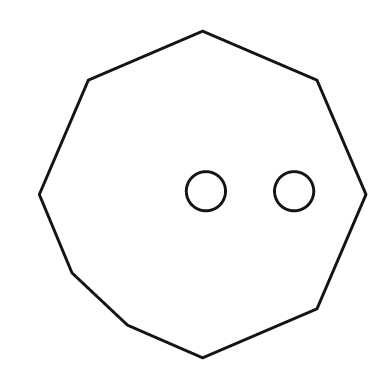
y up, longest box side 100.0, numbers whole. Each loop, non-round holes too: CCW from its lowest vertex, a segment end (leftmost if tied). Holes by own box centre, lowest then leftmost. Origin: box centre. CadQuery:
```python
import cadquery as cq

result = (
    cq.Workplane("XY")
    .moveTo(0.0, -50.0)
    .lineTo(35.0, -35.0)
    .lineTo(50.0, 0.0)
    .lineTo(35.0, 35.0)
    .lineTo(0.0, 50.0)
    .lineTo(-35.0, 35.0)
    .lineTo(-50.0, 0.0)
    .lineTo(-40.0, -24.0)
    .lineTo(-23.0, -40.0)
    .close()
    .moveTo(1.0, 1.0)
    .circle(6.0)
    .moveTo(28.0, 1.0)
    .circle(6.0)
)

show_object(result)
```